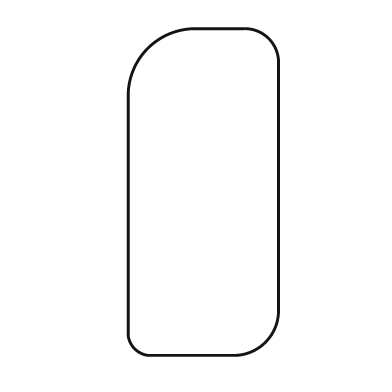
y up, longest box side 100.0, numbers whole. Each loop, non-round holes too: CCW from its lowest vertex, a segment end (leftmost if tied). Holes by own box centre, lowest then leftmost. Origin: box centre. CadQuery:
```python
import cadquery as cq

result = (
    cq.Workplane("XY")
    .moveTo(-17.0, -50.0)
    .lineTo(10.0, -50.0)
    .threePointArc((19.0, -46.0), (23.0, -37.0))
    .lineTo(23.0, 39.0)
    .threePointArc((20.0, 47.0), (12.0, 50.0))
    .lineTo(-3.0, 50.0)
    .threePointArc((-17.0, 44.0), (-23.0, 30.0))
    .lineTo(-23.0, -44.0)
    .threePointArc((-21.0, -48.0), (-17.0, -50.0))
    .close()
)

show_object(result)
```